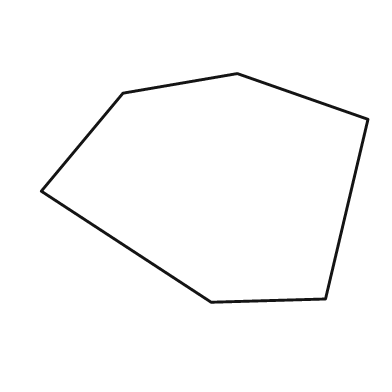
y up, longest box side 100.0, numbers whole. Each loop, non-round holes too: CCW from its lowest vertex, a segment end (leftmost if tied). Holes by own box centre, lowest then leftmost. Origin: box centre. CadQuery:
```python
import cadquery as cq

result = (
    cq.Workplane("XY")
    .moveTo(2.0, -35.0)
    .lineTo(37.0, -34.0)
    .lineTo(50.0, 21.0)
    .lineTo(10.0, 35.0)
    .lineTo(-25.0, 29.0)
    .lineTo(-50.0, -1.0)
    .close()
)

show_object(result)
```